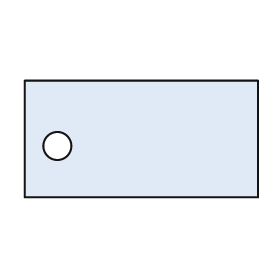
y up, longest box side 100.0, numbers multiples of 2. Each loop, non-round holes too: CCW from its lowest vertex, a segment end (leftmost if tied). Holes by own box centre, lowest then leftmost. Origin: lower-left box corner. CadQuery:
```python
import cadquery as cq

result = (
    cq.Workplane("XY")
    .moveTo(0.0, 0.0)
    .lineTo(100.0, 0.0)
    .lineTo(100.0, 50.0)
    .lineTo(0.0, 50.0)
    .close()
    .moveTo(14.0, 22.0)
    .circle(6.0)
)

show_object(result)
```